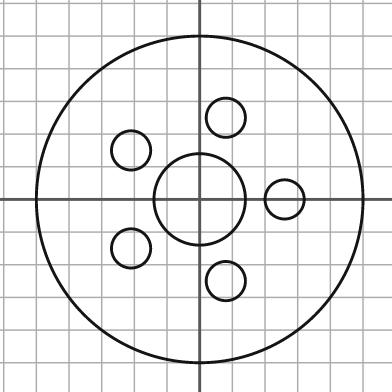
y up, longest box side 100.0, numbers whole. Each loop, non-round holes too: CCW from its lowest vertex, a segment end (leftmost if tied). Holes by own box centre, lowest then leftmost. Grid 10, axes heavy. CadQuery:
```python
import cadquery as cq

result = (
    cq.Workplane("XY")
    .moveTo(0.0, 0.0)
    .circle(50.0)
    .moveTo(8.0, -25.0)
    .circle(6.0)
    .moveTo(-21.0, -15.0)
    .circle(6.0)
    .moveTo(0.0, 0.0)
    .circle(14.0)
    .moveTo(26.0, 0.0)
    .circle(6.0)
    .moveTo(-21.0, 15.0)
    .circle(6.0)
    .moveTo(8.0, 25.0)
    .circle(6.0)
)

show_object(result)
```